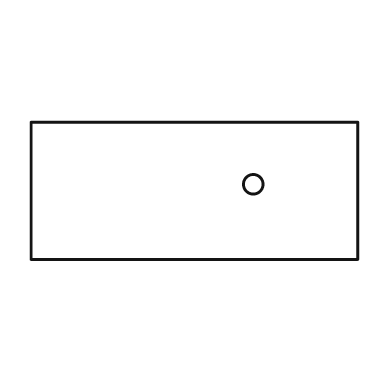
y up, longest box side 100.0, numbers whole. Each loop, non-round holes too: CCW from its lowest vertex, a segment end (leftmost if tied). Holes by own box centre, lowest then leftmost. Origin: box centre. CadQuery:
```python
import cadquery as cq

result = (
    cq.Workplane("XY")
    .moveTo(-50.0, -21.0)
    .lineTo(50.0, -21.0)
    .lineTo(50.0, 21.0)
    .lineTo(-50.0, 21.0)
    .close()
    .moveTo(18.0, 2.0)
    .circle(3.0)
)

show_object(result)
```